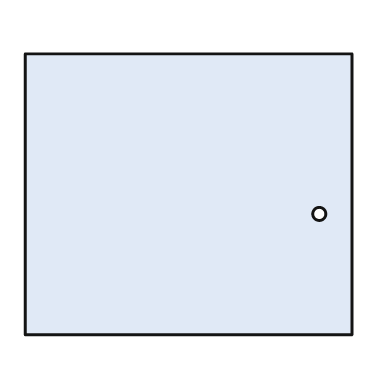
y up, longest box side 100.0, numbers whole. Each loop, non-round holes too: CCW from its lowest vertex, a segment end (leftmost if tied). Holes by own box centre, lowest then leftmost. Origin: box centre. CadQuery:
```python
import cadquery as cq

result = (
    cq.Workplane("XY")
    .moveTo(-50.0, -43.0)
    .lineTo(50.0, -43.0)
    .lineTo(50.0, 43.0)
    .lineTo(-50.0, 43.0)
    .close()
    .moveTo(40.0, -6.0)
    .circle(2.0)
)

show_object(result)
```